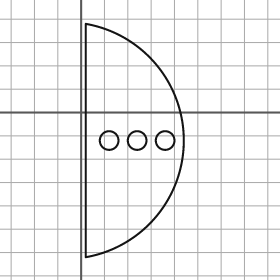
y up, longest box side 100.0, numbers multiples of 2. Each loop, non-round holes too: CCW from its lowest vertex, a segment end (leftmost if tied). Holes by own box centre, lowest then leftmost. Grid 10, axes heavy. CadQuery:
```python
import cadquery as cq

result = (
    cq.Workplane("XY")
    .moveTo(2.0, -62.0)
    .threePointArc((44.0, -12.0), (2.0, 38.0))
    .close()
    .moveTo(12.0, -12.0)
    .circle(4.0)
    .moveTo(24.0, -12.0)
    .circle(4.0)
    .moveTo(36.0, -12.0)
    .circle(4.0)
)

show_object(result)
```